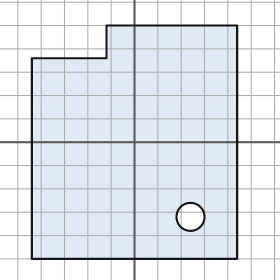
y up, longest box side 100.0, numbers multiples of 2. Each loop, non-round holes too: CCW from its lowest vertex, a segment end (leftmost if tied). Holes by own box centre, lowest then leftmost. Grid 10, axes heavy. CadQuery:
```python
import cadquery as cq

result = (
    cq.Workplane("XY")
    .moveTo(-44.0, -50.0)
    .lineTo(44.0, -50.0)
    .lineTo(44.0, 50.0)
    .lineTo(-12.0, 50.0)
    .lineTo(-12.0, 36.0)
    .lineTo(-44.0, 36.0)
    .close()
    .moveTo(24.0, -32.0)
    .circle(6.0)
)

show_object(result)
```